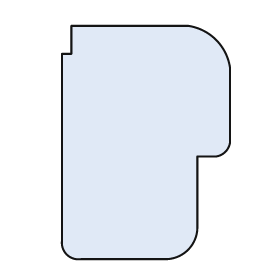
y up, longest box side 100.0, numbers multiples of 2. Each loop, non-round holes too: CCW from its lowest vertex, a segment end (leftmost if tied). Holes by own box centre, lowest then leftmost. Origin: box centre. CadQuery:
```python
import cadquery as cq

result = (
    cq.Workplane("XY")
    .moveTo(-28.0, -50.0)
    .lineTo(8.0, -50.0)
    .threePointArc((18.0, -46.0), (22.0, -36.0))
    .lineTo(22.0, -6.0)
    .lineTo(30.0, -6.0)
    .threePointArc((34.0, -4.0), (36.0, 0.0))
    .lineTo(36.0, 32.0)
    .threePointArc((30.0, 44.0), (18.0, 50.0))
    .lineTo(-32.0, 50.0)
    .lineTo(-32.0, 38.0)
    .lineTo(-36.0, 38.0)
    .lineTo(-36.0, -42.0)
    .threePointArc((-34.0, -48.0), (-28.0, -50.0))
    .close()
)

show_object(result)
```